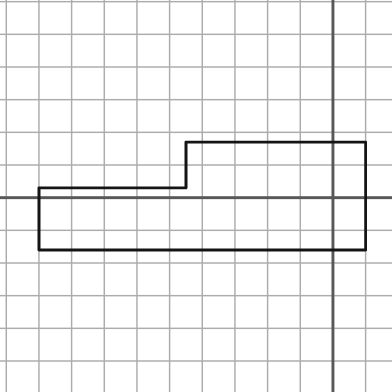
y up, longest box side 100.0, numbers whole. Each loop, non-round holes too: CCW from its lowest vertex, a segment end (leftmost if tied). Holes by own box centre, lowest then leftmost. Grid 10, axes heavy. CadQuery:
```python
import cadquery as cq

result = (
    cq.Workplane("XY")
    .moveTo(-90.0, -16.0)
    .lineTo(10.0, -16.0)
    .lineTo(10.0, 17.0)
    .lineTo(-45.0, 17.0)
    .lineTo(-45.0, 3.0)
    .lineTo(-90.0, 3.0)
    .close()
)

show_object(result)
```